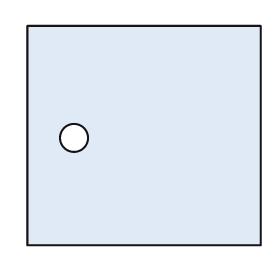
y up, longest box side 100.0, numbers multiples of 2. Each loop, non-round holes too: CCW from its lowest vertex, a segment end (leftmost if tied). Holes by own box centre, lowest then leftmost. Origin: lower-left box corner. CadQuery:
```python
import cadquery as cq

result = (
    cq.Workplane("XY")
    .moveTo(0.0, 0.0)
    .lineTo(100.0, 0.0)
    .lineTo(100.0, 94.0)
    .lineTo(0.0, 94.0)
    .close()
    .moveTo(20.0, 46.0)
    .circle(6.0)
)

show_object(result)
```